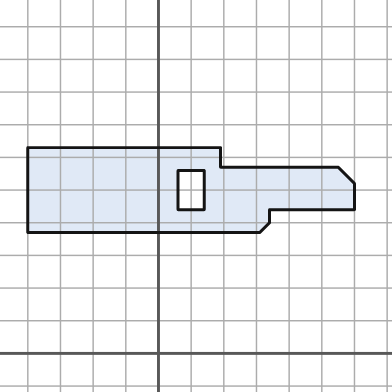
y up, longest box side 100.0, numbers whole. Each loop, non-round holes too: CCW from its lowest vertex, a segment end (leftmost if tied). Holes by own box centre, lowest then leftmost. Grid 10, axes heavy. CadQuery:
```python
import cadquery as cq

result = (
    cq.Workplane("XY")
    .moveTo(-40.0, 37.0)
    .lineTo(31.0, 37.0)
    .lineTo(34.0, 40.0)
    .lineTo(34.0, 44.0)
    .lineTo(60.0, 44.0)
    .lineTo(60.0, 52.0)
    .lineTo(55.0, 57.0)
    .lineTo(19.0, 57.0)
    .lineTo(19.0, 63.0)
    .lineTo(-40.0, 63.0)
    .close()
    .moveTo(6.0, 44.0)
    .lineTo(14.0, 44.0)
    .lineTo(14.0, 56.0)
    .lineTo(6.0, 56.0)
    .close()
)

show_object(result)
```